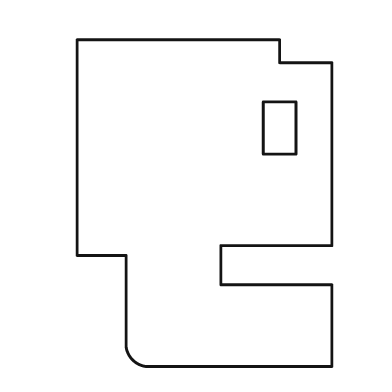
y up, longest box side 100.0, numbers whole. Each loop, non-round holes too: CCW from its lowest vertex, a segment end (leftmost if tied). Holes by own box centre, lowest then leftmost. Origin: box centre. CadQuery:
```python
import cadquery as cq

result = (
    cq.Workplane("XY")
    .moveTo(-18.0, -50.0)
    .lineTo(39.0, -50.0)
    .lineTo(39.0, -25.0)
    .lineTo(5.0, -25.0)
    .lineTo(5.0, -13.0)
    .lineTo(39.0, -13.0)
    .lineTo(39.0, 43.0)
    .lineTo(23.0, 43.0)
    .lineTo(23.0, 50.0)
    .lineTo(-39.0, 50.0)
    .lineTo(-39.0, -16.0)
    .lineTo(-24.0, -16.0)
    .lineTo(-24.0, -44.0)
    .threePointArc((-22.0, -48.0), (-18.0, -50.0))
    .close()
    .moveTo(18.0, 15.0)
    .lineTo(28.0, 15.0)
    .lineTo(28.0, 31.0)
    .lineTo(18.0, 31.0)
    .close()
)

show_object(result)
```